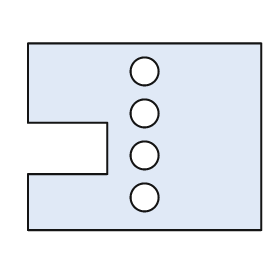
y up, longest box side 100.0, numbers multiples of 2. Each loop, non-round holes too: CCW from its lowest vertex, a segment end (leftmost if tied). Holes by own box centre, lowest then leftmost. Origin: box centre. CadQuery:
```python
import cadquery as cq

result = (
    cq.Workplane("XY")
    .moveTo(-50.0, -40.0)
    .lineTo(50.0, -40.0)
    .lineTo(50.0, 40.0)
    .lineTo(-50.0, 40.0)
    .lineTo(-50.0, 6.0)
    .lineTo(-16.0, 6.0)
    .lineTo(-16.0, -16.0)
    .lineTo(-50.0, -16.0)
    .close()
    .moveTo(0.0, -26.0)
    .circle(6.0)
    .moveTo(0.0, -8.0)
    .circle(6.0)
    .moveTo(0.0, 10.0)
    .circle(6.0)
    .moveTo(0.0, 28.0)
    .circle(6.0)
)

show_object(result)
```